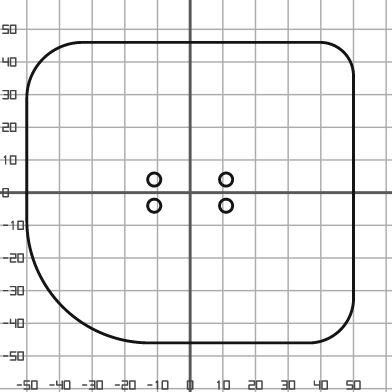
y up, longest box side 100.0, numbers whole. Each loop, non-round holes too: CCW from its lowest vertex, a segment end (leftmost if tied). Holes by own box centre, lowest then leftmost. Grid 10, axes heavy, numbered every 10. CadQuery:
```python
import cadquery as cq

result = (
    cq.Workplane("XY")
    .moveTo(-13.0, -46.0)
    .lineTo(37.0, -46.0)
    .threePointArc((46.0, -42.0), (50.0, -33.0))
    .lineTo(50.0, 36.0)
    .threePointArc((47.0, 43.0), (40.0, 46.0))
    .lineTo(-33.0, 46.0)
    .threePointArc((-45.0, 41.0), (-50.0, 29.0))
    .lineTo(-50.0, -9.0)
    .threePointArc((-39.0, -35.0), (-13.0, -46.0))
    .close()
    .moveTo(-11.0, -4.0)
    .circle(2.0)
    .moveTo(11.0, -4.0)
    .circle(2.0)
    .moveTo(-11.0, 4.0)
    .circle(2.0)
    .moveTo(11.0, 4.0)
    .circle(2.0)
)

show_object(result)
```